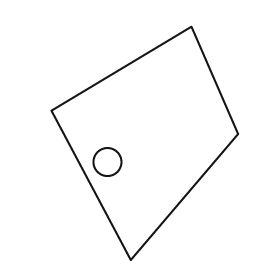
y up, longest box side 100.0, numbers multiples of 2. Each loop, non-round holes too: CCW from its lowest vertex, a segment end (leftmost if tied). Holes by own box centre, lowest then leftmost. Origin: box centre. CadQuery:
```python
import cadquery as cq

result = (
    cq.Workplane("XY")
    .moveTo(-6.0, -50.0)
    .lineTo(40.0, 4.0)
    .lineTo(20.0, 50.0)
    .lineTo(-40.0, 14.0)
    .close()
    .moveTo(-16.0, -8.0)
    .circle(6.0)
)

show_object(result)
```